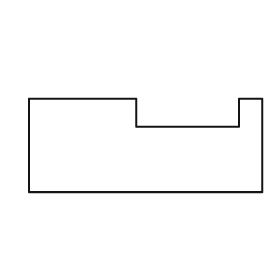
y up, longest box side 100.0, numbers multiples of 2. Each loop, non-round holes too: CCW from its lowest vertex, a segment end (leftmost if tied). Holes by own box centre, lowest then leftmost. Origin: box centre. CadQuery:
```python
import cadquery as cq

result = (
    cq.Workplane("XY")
    .moveTo(-50.0, -20.0)
    .lineTo(50.0, -20.0)
    .lineTo(50.0, 20.0)
    .lineTo(40.0, 20.0)
    .lineTo(40.0, 8.0)
    .lineTo(-4.0, 8.0)
    .lineTo(-4.0, 20.0)
    .lineTo(-50.0, 20.0)
    .close()
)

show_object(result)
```